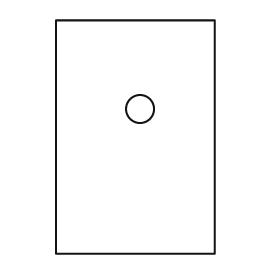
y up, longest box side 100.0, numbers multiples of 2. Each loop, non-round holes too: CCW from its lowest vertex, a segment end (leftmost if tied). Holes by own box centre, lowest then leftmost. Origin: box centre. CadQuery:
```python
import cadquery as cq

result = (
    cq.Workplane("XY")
    .moveTo(-34.0, -50.0)
    .lineTo(34.0, -50.0)
    .lineTo(34.0, 50.0)
    .lineTo(-34.0, 50.0)
    .close()
    .moveTo(2.0, 12.0)
    .circle(6.0)
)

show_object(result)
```